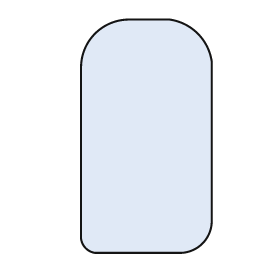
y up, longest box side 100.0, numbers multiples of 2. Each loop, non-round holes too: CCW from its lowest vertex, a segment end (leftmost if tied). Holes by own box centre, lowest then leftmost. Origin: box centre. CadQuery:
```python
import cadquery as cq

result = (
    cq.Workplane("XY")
    .moveTo(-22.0, -50.0)
    .lineTo(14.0, -50.0)
    .threePointArc((24.0, -46.0), (28.0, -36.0))
    .lineTo(28.0, 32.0)
    .threePointArc((22.0, 44.0), (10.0, 50.0))
    .lineTo(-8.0, 50.0)
    .threePointArc((-22.0, 44.0), (-28.0, 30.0))
    .lineTo(-28.0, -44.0)
    .threePointArc((-26.0, -48.0), (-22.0, -50.0))
    .close()
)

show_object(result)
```